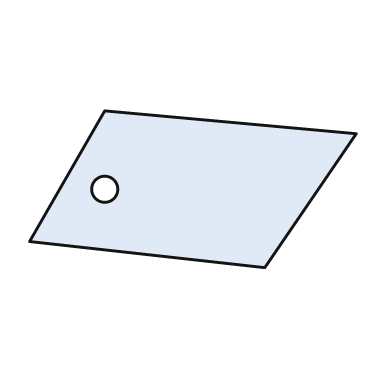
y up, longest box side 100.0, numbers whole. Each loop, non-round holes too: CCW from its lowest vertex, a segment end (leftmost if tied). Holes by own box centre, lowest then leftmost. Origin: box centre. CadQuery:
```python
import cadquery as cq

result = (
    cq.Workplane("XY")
    .moveTo(22.0, -24.0)
    .lineTo(50.0, 17.0)
    .lineTo(-27.0, 24.0)
    .lineTo(-50.0, -16.0)
    .close()
    .moveTo(-27.0, 0.0)
    .circle(4.0)
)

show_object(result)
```